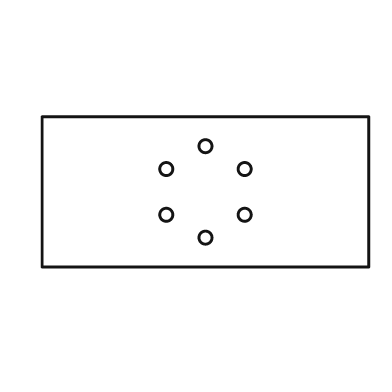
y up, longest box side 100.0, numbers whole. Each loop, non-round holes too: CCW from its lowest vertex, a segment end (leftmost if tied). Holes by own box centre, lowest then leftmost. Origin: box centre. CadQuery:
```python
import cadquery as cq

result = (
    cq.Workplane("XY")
    .moveTo(-50.0, -23.0)
    .lineTo(50.0, -23.0)
    .lineTo(50.0, 23.0)
    .lineTo(-50.0, 23.0)
    .close()
    .moveTo(0.0, -14.0)
    .circle(2.0)
    .moveTo(-12.0, -7.0)
    .circle(2.0)
    .moveTo(12.0, -7.0)
    .circle(2.0)
    .moveTo(-12.0, 7.0)
    .circle(2.0)
    .moveTo(12.0, 7.0)
    .circle(2.0)
    .moveTo(0.0, 14.0)
    .circle(2.0)
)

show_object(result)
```